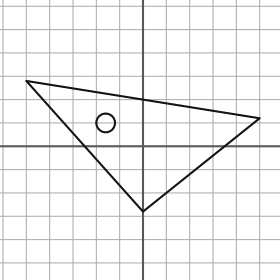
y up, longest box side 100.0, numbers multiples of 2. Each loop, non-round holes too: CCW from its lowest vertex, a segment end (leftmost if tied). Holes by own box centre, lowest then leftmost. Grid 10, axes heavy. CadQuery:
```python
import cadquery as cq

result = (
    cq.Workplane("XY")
    .moveTo(0.0, -28.0)
    .lineTo(50.0, 12.0)
    .lineTo(-50.0, 28.0)
    .close()
    .moveTo(-16.0, 10.0)
    .circle(4.0)
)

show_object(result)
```